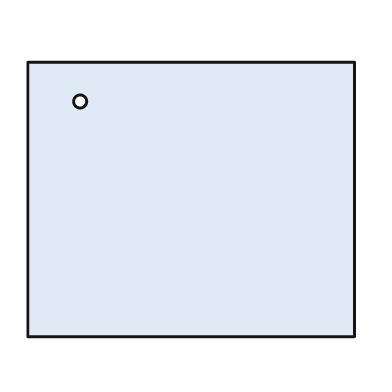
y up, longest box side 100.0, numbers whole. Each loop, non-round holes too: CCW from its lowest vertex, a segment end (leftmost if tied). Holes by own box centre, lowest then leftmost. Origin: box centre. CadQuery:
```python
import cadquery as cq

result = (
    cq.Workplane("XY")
    .moveTo(-50.0, -42.0)
    .lineTo(50.0, -42.0)
    .lineTo(50.0, 42.0)
    .lineTo(-50.0, 42.0)
    .close()
    .moveTo(-34.0, 30.0)
    .circle(2.0)
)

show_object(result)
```